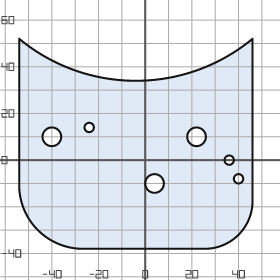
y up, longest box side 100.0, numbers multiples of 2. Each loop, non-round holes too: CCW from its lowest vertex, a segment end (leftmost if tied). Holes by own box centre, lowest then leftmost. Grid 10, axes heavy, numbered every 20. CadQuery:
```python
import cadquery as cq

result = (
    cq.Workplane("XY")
    .moveTo(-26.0, -38.0)
    .lineTo(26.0, -38.0)
    .threePointArc((40.0, -32.0), (46.0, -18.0))
    .lineTo(46.0, 52.0)
    .threePointArc((-4.0, 34.0), (-54.0, 52.0))
    .lineTo(-54.0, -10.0)
    .threePointArc((-46.0, -30.0), (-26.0, -38.0))
    .close()
    .moveTo(4.0, -10.0)
    .circle(4.0)
    .moveTo(40.0, -8.0)
    .circle(2.0)
    .moveTo(36.0, 0.0)
    .circle(2.0)
    .moveTo(-40.0, 10.0)
    .circle(4.0)
    .moveTo(22.0, 10.0)
    .circle(4.0)
    .moveTo(-24.0, 14.0)
    .circle(2.0)
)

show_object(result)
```